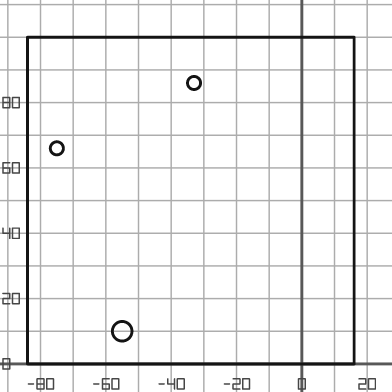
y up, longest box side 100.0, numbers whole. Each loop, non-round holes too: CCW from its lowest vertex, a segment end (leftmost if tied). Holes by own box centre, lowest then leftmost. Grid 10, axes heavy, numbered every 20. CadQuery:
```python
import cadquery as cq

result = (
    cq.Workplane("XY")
    .moveTo(-84.0, 0.0)
    .lineTo(16.0, 0.0)
    .lineTo(16.0, 100.0)
    .lineTo(-84.0, 100.0)
    .close()
    .moveTo(-55.0, 10.0)
    .circle(3.0)
    .moveTo(-75.0, 66.0)
    .circle(2.0)
    .moveTo(-33.0, 86.0)
    .circle(2.0)
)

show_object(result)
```